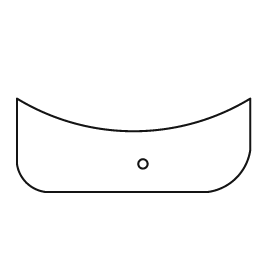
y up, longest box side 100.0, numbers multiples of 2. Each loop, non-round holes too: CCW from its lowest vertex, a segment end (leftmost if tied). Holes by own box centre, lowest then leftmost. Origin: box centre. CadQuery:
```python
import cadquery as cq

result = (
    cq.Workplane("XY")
    .moveTo(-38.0, -20.0)
    .lineTo(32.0, -20.0)
    .threePointArc((44.0, -14.0), (50.0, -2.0))
    .lineTo(50.0, 20.0)
    .threePointArc((0.0, 6.0), (-50.0, 20.0))
    .lineTo(-50.0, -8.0)
    .threePointArc((-46.0, -16.0), (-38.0, -20.0))
    .close()
    .moveTo(4.0, -8.0)
    .circle(2.0)
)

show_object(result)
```